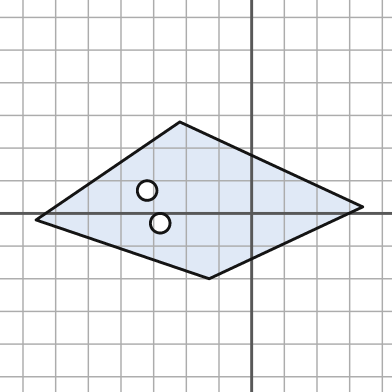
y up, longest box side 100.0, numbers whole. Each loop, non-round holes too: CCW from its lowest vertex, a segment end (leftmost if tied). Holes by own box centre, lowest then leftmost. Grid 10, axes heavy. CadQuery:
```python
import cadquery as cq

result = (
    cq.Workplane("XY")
    .moveTo(-13.0, -20.0)
    .lineTo(34.0, 2.0)
    .lineTo(-22.0, 28.0)
    .lineTo(-66.0, -2.0)
    .close()
    .moveTo(-28.0, -3.0)
    .circle(3.0)
    .moveTo(-32.0, 7.0)
    .circle(3.0)
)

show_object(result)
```